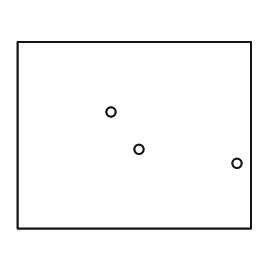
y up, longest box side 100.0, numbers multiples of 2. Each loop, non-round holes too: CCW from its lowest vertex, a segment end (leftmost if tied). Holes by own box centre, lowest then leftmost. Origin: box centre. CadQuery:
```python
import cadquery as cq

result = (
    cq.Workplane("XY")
    .moveTo(-50.0, -40.0)
    .lineTo(50.0, -40.0)
    .lineTo(50.0, 40.0)
    .lineTo(-50.0, 40.0)
    .close()
    .moveTo(44.0, -12.0)
    .circle(2.0)
    .moveTo(2.0, -6.0)
    .circle(2.0)
    .moveTo(-10.0, 10.0)
    .circle(2.0)
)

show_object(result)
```